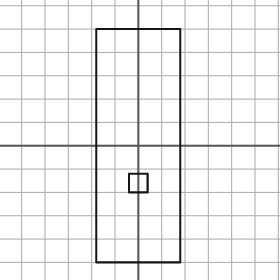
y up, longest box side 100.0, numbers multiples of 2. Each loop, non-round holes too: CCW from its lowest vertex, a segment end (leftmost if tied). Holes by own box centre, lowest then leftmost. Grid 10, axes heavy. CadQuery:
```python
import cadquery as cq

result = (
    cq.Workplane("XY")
    .moveTo(-18.0, -50.0)
    .lineTo(18.0, -50.0)
    .lineTo(18.0, 50.0)
    .lineTo(-18.0, 50.0)
    .close()
    .moveTo(-4.0, -20.0)
    .lineTo(4.0, -20.0)
    .lineTo(4.0, -12.0)
    .lineTo(-4.0, -12.0)
    .close()
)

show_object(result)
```